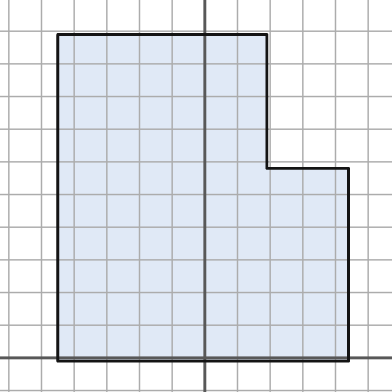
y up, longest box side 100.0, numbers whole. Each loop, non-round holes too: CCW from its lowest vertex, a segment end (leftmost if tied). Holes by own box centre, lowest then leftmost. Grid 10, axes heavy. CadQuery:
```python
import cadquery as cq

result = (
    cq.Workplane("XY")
    .moveTo(-45.0, -1.0)
    .lineTo(44.0, -1.0)
    .lineTo(44.0, 58.0)
    .lineTo(19.0, 58.0)
    .lineTo(19.0, 99.0)
    .lineTo(-45.0, 99.0)
    .close()
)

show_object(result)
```